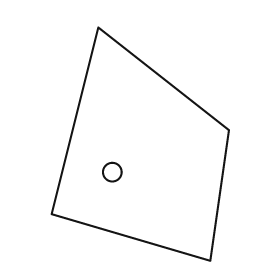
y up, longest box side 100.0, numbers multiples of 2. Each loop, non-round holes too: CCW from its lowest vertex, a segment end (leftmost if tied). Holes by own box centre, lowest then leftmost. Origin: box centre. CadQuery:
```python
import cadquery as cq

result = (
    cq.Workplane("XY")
    .moveTo(30.0, -50.0)
    .lineTo(38.0, 6.0)
    .lineTo(-18.0, 50.0)
    .lineTo(-38.0, -30.0)
    .close()
    .moveTo(-12.0, -12.0)
    .circle(4.0)
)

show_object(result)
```